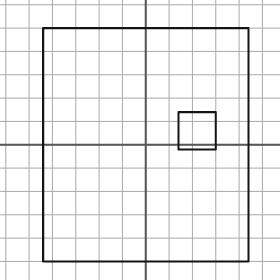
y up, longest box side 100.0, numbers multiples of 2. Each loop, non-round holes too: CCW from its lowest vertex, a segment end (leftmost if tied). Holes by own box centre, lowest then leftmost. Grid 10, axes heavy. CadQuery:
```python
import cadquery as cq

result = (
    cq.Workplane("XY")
    .moveTo(-44.0, -50.0)
    .lineTo(44.0, -50.0)
    .lineTo(44.0, 50.0)
    .lineTo(-44.0, 50.0)
    .close()
    .moveTo(14.0, -2.0)
    .lineTo(30.0, -2.0)
    .lineTo(30.0, 14.0)
    .lineTo(14.0, 14.0)
    .close()
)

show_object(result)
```